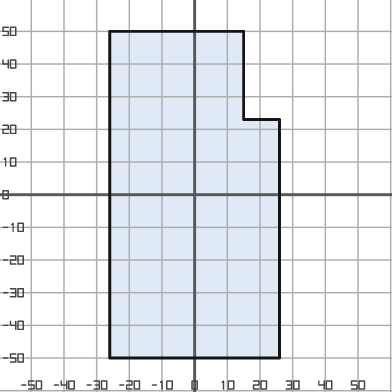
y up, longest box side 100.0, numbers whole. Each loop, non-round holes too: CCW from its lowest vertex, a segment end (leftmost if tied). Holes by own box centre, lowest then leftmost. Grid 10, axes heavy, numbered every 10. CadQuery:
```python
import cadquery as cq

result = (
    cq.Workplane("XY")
    .moveTo(-26.0, -50.0)
    .lineTo(26.0, -50.0)
    .lineTo(26.0, 23.0)
    .lineTo(15.0, 23.0)
    .lineTo(15.0, 50.0)
    .lineTo(-26.0, 50.0)
    .close()
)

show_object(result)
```